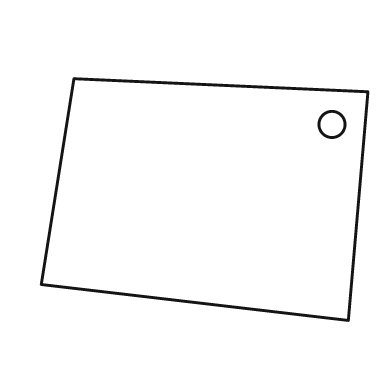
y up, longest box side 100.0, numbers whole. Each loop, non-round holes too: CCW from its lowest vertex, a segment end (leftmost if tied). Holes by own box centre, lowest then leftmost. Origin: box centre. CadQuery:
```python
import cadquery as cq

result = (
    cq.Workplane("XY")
    .moveTo(44.0, -37.0)
    .lineTo(50.0, 33.0)
    .lineTo(-40.0, 37.0)
    .lineTo(-50.0, -26.0)
    .close()
    .moveTo(39.0, 23.0)
    .circle(4.0)
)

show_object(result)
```